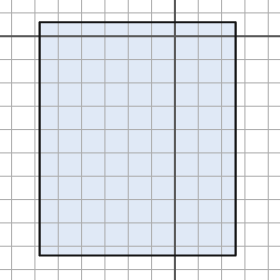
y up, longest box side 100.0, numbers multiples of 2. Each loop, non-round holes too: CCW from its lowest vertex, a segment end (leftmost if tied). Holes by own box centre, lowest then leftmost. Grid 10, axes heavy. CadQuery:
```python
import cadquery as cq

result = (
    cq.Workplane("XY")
    .moveTo(-58.0, -94.0)
    .lineTo(26.0, -94.0)
    .lineTo(26.0, 6.0)
    .lineTo(-58.0, 6.0)
    .close()
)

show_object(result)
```